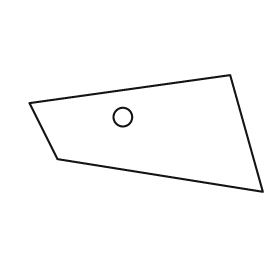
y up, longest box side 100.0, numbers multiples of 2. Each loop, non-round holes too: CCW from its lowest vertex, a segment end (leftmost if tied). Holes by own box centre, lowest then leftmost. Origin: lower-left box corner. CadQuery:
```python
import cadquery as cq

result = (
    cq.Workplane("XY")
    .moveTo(100.0, 0.0)
    .lineTo(86.0, 50.0)
    .lineTo(0.0, 38.0)
    .lineTo(12.0, 14.0)
    .close()
    .moveTo(40.0, 32.0)
    .circle(4.0)
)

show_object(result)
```